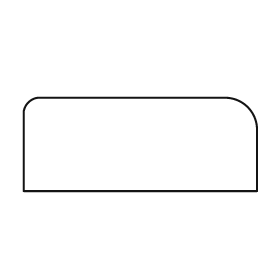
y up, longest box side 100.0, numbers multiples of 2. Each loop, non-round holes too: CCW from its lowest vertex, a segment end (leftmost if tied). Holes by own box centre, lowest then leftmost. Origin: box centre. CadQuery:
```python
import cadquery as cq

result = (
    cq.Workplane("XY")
    .moveTo(-50.0, -20.0)
    .lineTo(50.0, -20.0)
    .lineTo(50.0, 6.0)
    .threePointArc((46.0, 16.0), (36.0, 20.0))
    .lineTo(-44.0, 20.0)
    .threePointArc((-48.0, 18.0), (-50.0, 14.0))
    .close()
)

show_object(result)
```